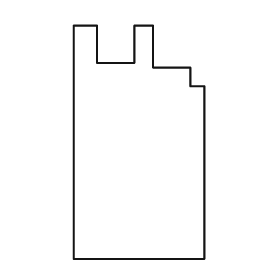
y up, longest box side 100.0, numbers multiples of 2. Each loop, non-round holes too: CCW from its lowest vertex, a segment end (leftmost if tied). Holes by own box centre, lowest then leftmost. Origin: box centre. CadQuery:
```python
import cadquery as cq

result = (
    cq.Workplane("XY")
    .moveTo(-28.0, -50.0)
    .lineTo(28.0, -50.0)
    .lineTo(28.0, 24.0)
    .lineTo(22.0, 24.0)
    .lineTo(22.0, 32.0)
    .lineTo(6.0, 32.0)
    .lineTo(6.0, 50.0)
    .lineTo(-2.0, 50.0)
    .lineTo(-2.0, 34.0)
    .lineTo(-18.0, 34.0)
    .lineTo(-18.0, 50.0)
    .lineTo(-28.0, 50.0)
    .close()
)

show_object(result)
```